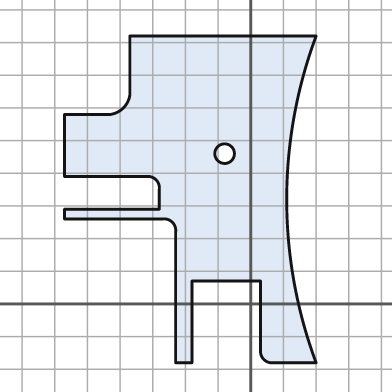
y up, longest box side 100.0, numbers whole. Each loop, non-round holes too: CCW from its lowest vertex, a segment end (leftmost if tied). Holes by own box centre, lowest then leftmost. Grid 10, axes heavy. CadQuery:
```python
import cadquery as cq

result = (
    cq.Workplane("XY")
    .moveTo(-23.0, -18.0)
    .lineTo(-18.0, -18.0)
    .lineTo(-18.0, 7.0)
    .lineTo(3.0, 7.0)
    .lineTo(3.0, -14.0)
    .threePointArc((4.0, -17.0), (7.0, -18.0))
    .lineTo(20.0, -18.0)
    .threePointArc((11.0, 32.0), (20.0, 82.0))
    .lineTo(-37.0, 82.0)
    .lineTo(-37.0, 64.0)
    .threePointArc((-39.0, 60.0), (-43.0, 58.0))
    .lineTo(-57.0, 58.0)
    .lineTo(-57.0, 39.0)
    .lineTo(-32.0, 39.0)
    .threePointArc((-29.0, 38.0), (-28.0, 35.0))
    .lineTo(-28.0, 29.0)
    .lineTo(-57.0, 29.0)
    .lineTo(-57.0, 26.0)
    .lineTo(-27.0, 26.0)
    .threePointArc((-24.0, 25.0), (-23.0, 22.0))
    .close()
    .moveTo(-8.0, 46.0)
    .circle(3.0)
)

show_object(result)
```